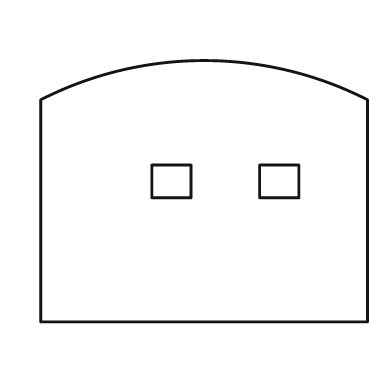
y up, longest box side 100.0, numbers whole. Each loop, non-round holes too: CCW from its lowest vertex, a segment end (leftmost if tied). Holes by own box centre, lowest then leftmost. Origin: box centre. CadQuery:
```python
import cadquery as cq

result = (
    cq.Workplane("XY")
    .moveTo(-50.0, -40.0)
    .lineTo(50.0, -40.0)
    .lineTo(50.0, 28.0)
    .threePointArc((0.0, 40.0), (-50.0, 28.0))
    .close()
    .moveTo(-16.0, -2.0)
    .lineTo(-4.0, -2.0)
    .lineTo(-4.0, 8.0)
    .lineTo(-16.0, 8.0)
    .close()
    .moveTo(17.0, -2.0)
    .lineTo(29.0, -2.0)
    .lineTo(29.0, 8.0)
    .lineTo(17.0, 8.0)
    .close()
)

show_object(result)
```